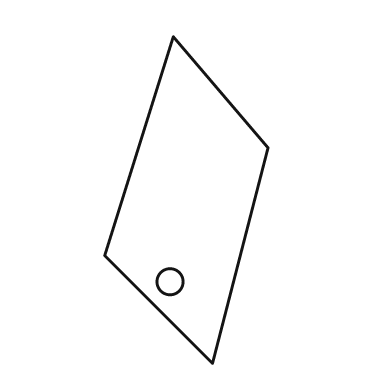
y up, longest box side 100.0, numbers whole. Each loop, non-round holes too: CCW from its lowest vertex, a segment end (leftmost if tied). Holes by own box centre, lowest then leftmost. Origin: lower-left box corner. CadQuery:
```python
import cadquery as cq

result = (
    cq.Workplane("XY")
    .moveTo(33.0, 0.0)
    .lineTo(50.0, 66.0)
    .lineTo(21.0, 100.0)
    .lineTo(0.0, 33.0)
    .close()
    .moveTo(20.0, 25.0)
    .circle(4.0)
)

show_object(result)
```